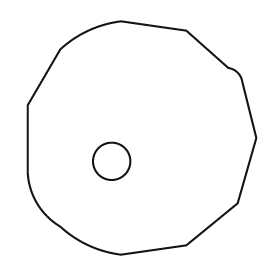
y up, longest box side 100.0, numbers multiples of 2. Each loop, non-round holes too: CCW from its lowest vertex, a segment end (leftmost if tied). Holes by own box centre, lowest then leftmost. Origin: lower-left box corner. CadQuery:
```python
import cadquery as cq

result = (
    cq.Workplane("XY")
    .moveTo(40.0, 0.0)
    .lineTo(68.0, 4.0)
    .lineTo(90.0, 22.0)
    .lineTo(98.0, 50.0)
    .lineTo(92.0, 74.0)
    .threePointArc((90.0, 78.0), (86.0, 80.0))
    .lineTo(68.0, 96.0)
    .lineTo(40.0, 100.0)
    .threePointArc((26.0, 96.0), (14.0, 88.0))
    .lineTo(0.0, 64.0)
    .lineTo(0.0, 36.0)
    .threePointArc((4.0, 22.0), (14.0, 12.0))
    .threePointArc((26.0, 4.0), (40.0, 0.0))
    .close()
    .moveTo(36.0, 40.0)
    .circle(8.0)
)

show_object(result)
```